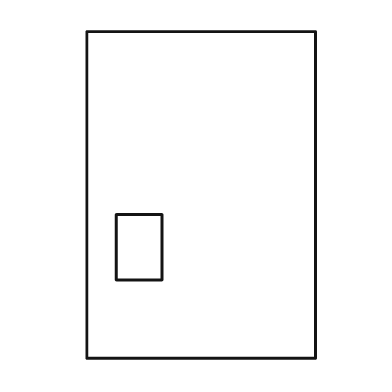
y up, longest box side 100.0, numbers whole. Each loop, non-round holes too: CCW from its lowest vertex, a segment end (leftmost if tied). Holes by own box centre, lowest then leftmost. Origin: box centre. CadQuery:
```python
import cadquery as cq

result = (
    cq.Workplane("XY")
    .moveTo(-35.0, -50.0)
    .lineTo(35.0, -50.0)
    .lineTo(35.0, 50.0)
    .lineTo(-35.0, 50.0)
    .close()
    .moveTo(-26.0, -26.0)
    .lineTo(-12.0, -26.0)
    .lineTo(-12.0, -6.0)
    .lineTo(-26.0, -6.0)
    .close()
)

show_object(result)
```